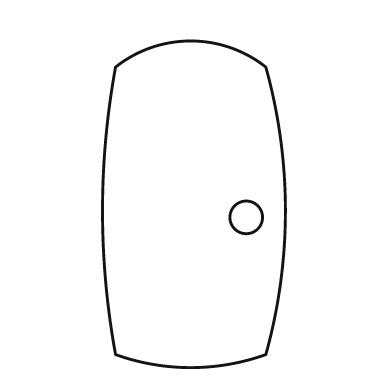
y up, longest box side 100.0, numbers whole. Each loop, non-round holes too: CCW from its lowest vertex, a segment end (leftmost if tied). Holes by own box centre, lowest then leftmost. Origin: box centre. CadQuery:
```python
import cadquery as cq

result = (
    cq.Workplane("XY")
    .moveTo(-24.0, -46.0)
    .threePointArc((-1.0, -50.0), (22.0, -46.0))
    .threePointArc((28.0, -2.0), (22.0, 42.0))
    .threePointArc((-1.0, 50.0), (-24.0, 42.0))
    .threePointArc((-28.0, -2.0), (-24.0, -46.0))
    .close()
    .moveTo(16.0, -4.0)
    .circle(5.0)
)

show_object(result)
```